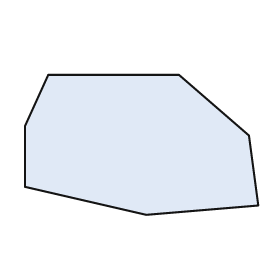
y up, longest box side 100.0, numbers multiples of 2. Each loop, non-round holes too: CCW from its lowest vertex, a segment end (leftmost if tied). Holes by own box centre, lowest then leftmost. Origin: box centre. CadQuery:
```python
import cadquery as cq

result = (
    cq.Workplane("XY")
    .moveTo(2.0, -30.0)
    .lineTo(50.0, -26.0)
    .lineTo(46.0, 4.0)
    .lineTo(16.0, 30.0)
    .lineTo(-40.0, 30.0)
    .lineTo(-50.0, 8.0)
    .lineTo(-50.0, -18.0)
    .close()
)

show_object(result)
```